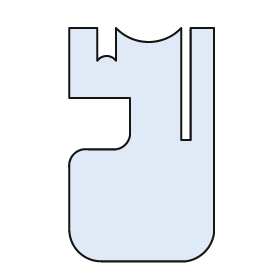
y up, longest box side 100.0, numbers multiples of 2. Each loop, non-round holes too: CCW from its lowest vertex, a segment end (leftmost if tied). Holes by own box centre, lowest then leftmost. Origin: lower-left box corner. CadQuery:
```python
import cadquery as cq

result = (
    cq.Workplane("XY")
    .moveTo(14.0, 0.0)
    .lineTo(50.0, 0.0)
    .threePointArc((58.0, 4.0), (62.0, 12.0))
    .lineTo(62.0, 100.0)
    .lineTo(52.0, 100.0)
    .lineTo(52.0, 52.0)
    .lineTo(48.0, 52.0)
    .lineTo(48.0, 100.0)
    .threePointArc((34.0, 94.0), (20.0, 100.0))
    .lineTo(20.0, 86.0)
    .threePointArc((16.0, 88.0), (12.0, 86.0))
    .lineTo(12.0, 100.0)
    .lineTo(0.0, 100.0)
    .lineTo(0.0, 70.0)
    .lineTo(26.0, 70.0)
    .lineTo(26.0, 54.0)
    .threePointArc((24.0, 50.0), (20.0, 48.0))
    .lineTo(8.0, 48.0)
    .threePointArc((2.0, 46.0), (0.0, 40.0))
    .lineTo(0.0, 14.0)
    .threePointArc((4.0, 4.0), (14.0, 0.0))
    .close()
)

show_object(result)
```